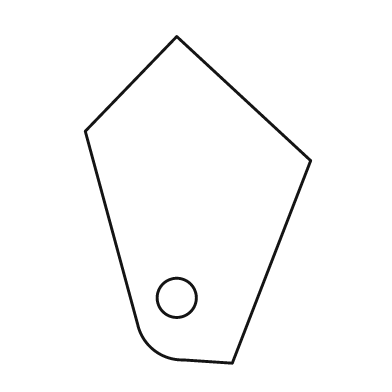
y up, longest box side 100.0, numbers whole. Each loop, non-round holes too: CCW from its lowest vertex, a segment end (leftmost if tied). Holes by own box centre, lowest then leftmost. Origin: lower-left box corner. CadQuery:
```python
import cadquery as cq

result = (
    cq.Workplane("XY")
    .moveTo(45.0, 0.0)
    .lineTo(69.0, 62.0)
    .lineTo(28.0, 100.0)
    .lineTo(0.0, 71.0)
    .lineTo(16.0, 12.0)
    .threePointArc((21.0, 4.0), (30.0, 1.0))
    .close()
    .moveTo(28.0, 20.0)
    .circle(6.0)
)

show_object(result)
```